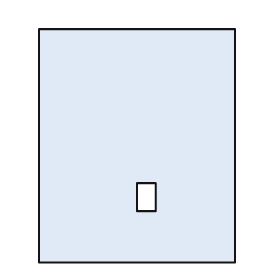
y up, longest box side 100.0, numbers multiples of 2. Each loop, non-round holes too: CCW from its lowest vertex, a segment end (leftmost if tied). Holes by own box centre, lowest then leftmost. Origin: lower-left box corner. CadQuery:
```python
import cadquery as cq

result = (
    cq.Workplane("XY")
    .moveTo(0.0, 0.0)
    .lineTo(84.0, 0.0)
    .lineTo(84.0, 100.0)
    .lineTo(0.0, 100.0)
    .close()
    .moveTo(42.0, 22.0)
    .lineTo(50.0, 22.0)
    .lineTo(50.0, 34.0)
    .lineTo(42.0, 34.0)
    .close()
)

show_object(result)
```